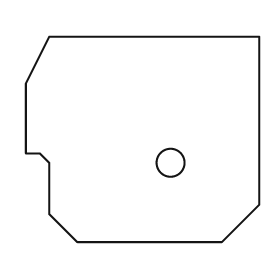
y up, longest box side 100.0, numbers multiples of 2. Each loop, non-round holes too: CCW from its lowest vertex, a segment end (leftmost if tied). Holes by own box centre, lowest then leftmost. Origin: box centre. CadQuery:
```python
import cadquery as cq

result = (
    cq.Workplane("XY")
    .moveTo(-28.0, -44.0)
    .lineTo(34.0, -44.0)
    .lineTo(50.0, -28.0)
    .lineTo(50.0, 44.0)
    .lineTo(-40.0, 44.0)
    .lineTo(-50.0, 24.0)
    .lineTo(-50.0, -6.0)
    .lineTo(-44.0, -6.0)
    .lineTo(-40.0, -10.0)
    .lineTo(-40.0, -32.0)
    .close()
    .moveTo(12.0, -10.0)
    .circle(6.0)
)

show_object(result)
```